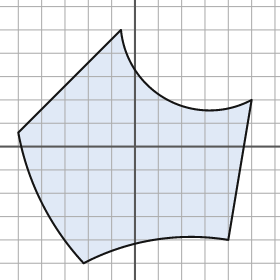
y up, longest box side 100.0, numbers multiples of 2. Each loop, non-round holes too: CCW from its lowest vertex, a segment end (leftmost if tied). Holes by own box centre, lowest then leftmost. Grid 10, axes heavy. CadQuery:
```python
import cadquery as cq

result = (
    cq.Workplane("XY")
    .moveTo(-22.0, -50.0)
    .threePointArc((8.0, -40.0), (40.0, -40.0))
    .lineTo(50.0, 20.0)
    .threePointArc((14.0, 20.0), (-6.0, 50.0))
    .lineTo(-50.0, 6.0)
    .threePointArc((-40.0, -24.0), (-22.0, -50.0))
    .close()
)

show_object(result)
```